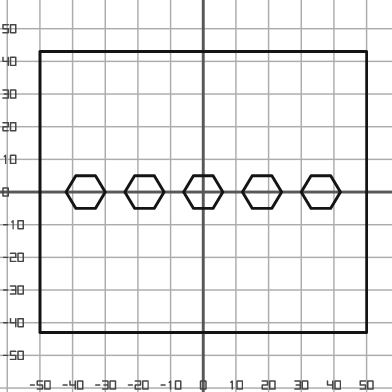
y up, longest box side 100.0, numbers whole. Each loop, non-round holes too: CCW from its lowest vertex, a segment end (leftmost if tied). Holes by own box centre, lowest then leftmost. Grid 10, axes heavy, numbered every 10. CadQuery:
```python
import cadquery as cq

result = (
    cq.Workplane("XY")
    .moveTo(-50.0, -43.0)
    .lineTo(50.0, -43.0)
    .lineTo(50.0, 43.0)
    .lineTo(-50.0, 43.0)
    .close()
    .moveTo(-39.0, -5.0)
    .lineTo(-33.0, -5.0)
    .lineTo(-30.0, 0.0)
    .lineTo(-33.0, 5.0)
    .lineTo(-39.0, 5.0)
    .lineTo(-42.0, 0.0)
    .close()
    .moveTo(-21.0, -5.0)
    .lineTo(-15.0, -5.0)
    .lineTo(-12.0, 0.0)
    .lineTo(-15.0, 5.0)
    .lineTo(-21.0, 5.0)
    .lineTo(-24.0, 0.0)
    .close()
    .moveTo(-3.0, -5.0)
    .lineTo(3.0, -5.0)
    .lineTo(6.0, 0.0)
    .lineTo(3.0, 5.0)
    .lineTo(-3.0, 5.0)
    .lineTo(-6.0, 0.0)
    .close()
    .moveTo(15.0, -5.0)
    .lineTo(21.0, -5.0)
    .lineTo(24.0, 0.0)
    .lineTo(21.0, 5.0)
    .lineTo(15.0, 5.0)
    .lineTo(12.0, 0.0)
    .close()
    .moveTo(33.0, -5.0)
    .lineTo(39.0, -5.0)
    .lineTo(42.0, 0.0)
    .lineTo(39.0, 5.0)
    .lineTo(33.0, 5.0)
    .lineTo(30.0, 0.0)
    .close()
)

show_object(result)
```